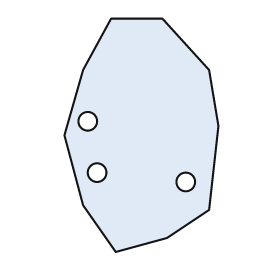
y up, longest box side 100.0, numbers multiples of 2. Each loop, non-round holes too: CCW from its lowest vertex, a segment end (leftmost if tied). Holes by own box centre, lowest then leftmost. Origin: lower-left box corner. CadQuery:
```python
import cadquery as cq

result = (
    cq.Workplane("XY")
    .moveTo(22.0, 0.0)
    .lineTo(44.0, 6.0)
    .lineTo(62.0, 18.0)
    .lineTo(66.0, 54.0)
    .lineTo(62.0, 78.0)
    .lineTo(42.0, 100.0)
    .lineTo(20.0, 100.0)
    .lineTo(8.0, 78.0)
    .lineTo(0.0, 50.0)
    .lineTo(8.0, 20.0)
    .close()
    .moveTo(52.0, 30.0)
    .circle(4.0)
    .moveTo(14.0, 34.0)
    .circle(4.0)
    .moveTo(10.0, 56.0)
    .circle(4.0)
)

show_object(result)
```